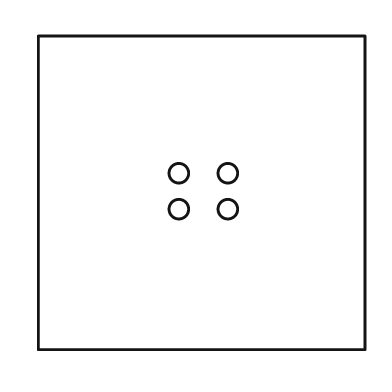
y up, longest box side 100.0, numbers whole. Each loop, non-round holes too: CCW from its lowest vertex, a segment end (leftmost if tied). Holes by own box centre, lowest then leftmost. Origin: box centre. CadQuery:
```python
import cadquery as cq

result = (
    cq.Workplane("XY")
    .moveTo(-50.0, -48.0)
    .lineTo(50.0, -48.0)
    .lineTo(50.0, 48.0)
    .lineTo(-50.0, 48.0)
    .close()
    .moveTo(-7.0, -5.0)
    .circle(3.0)
    .moveTo(8.0, -5.0)
    .circle(3.0)
    .moveTo(-7.0, 6.0)
    .circle(3.0)
    .moveTo(8.0, 6.0)
    .circle(3.0)
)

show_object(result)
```